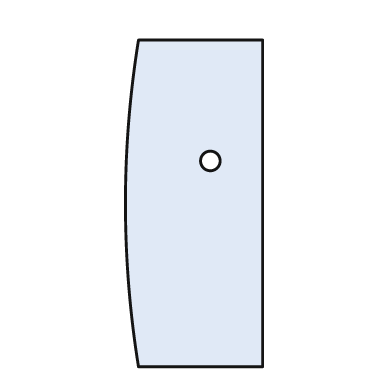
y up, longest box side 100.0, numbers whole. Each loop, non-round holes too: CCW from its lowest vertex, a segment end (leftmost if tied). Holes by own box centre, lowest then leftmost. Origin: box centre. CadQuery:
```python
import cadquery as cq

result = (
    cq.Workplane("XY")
    .moveTo(-17.0, -50.0)
    .lineTo(21.0, -50.0)
    .lineTo(21.0, 50.0)
    .lineTo(-17.0, 50.0)
    .threePointArc((-21.0, 0.0), (-17.0, -50.0))
    .close()
    .moveTo(5.0, 13.0)
    .circle(3.0)
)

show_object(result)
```